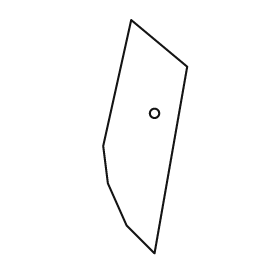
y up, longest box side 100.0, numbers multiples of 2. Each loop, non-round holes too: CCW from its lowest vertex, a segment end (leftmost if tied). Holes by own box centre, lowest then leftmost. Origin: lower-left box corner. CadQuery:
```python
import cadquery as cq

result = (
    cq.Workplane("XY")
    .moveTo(22.0, 0.0)
    .lineTo(36.0, 80.0)
    .lineTo(12.0, 100.0)
    .lineTo(0.0, 46.0)
    .lineTo(2.0, 30.0)
    .lineTo(10.0, 12.0)
    .close()
    .moveTo(22.0, 60.0)
    .circle(2.0)
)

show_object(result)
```